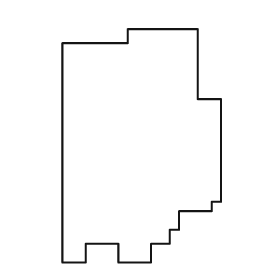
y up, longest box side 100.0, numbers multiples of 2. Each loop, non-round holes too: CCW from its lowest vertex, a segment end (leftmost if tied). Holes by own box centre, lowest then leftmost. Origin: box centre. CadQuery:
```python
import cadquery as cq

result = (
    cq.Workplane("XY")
    .moveTo(-34.0, -50.0)
    .lineTo(-24.0, -50.0)
    .lineTo(-24.0, -42.0)
    .lineTo(-10.0, -42.0)
    .lineTo(-10.0, -50.0)
    .lineTo(4.0, -50.0)
    .lineTo(4.0, -42.0)
    .lineTo(12.0, -42.0)
    .lineTo(12.0, -36.0)
    .lineTo(16.0, -36.0)
    .lineTo(16.0, -28.0)
    .lineTo(30.0, -28.0)
    .lineTo(30.0, -24.0)
    .lineTo(34.0, -24.0)
    .lineTo(34.0, 20.0)
    .lineTo(24.0, 20.0)
    .lineTo(24.0, 50.0)
    .lineTo(-6.0, 50.0)
    .lineTo(-6.0, 44.0)
    .lineTo(-34.0, 44.0)
    .close()
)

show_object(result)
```